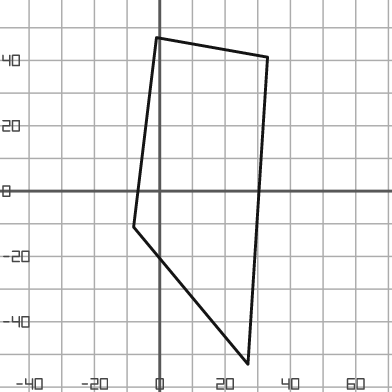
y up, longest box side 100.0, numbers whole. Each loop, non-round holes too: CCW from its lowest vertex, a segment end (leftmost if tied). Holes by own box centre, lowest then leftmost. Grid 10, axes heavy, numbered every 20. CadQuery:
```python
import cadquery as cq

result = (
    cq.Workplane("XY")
    .moveTo(27.0, -53.0)
    .lineTo(33.0, 41.0)
    .lineTo(-1.0, 47.0)
    .lineTo(-8.0, -11.0)
    .close()
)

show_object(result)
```